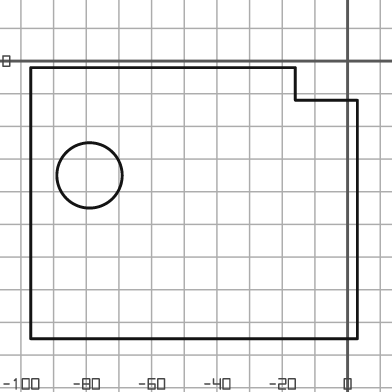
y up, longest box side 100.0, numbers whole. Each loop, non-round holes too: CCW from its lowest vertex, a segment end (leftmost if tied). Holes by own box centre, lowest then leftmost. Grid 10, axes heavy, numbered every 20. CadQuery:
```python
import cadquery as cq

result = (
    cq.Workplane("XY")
    .moveTo(-97.0, -85.0)
    .lineTo(3.0, -85.0)
    .lineTo(3.0, -12.0)
    .lineTo(-16.0, -12.0)
    .lineTo(-16.0, -2.0)
    .lineTo(-97.0, -2.0)
    .close()
    .moveTo(-79.0, -35.0)
    .circle(10.0)
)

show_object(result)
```